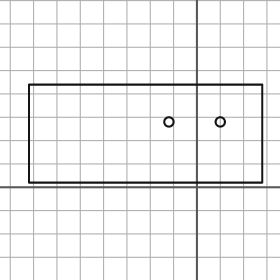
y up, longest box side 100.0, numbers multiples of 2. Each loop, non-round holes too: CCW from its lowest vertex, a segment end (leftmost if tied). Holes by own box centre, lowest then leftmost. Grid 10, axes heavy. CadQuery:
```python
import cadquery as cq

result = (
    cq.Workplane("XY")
    .moveTo(-72.0, 2.0)
    .lineTo(28.0, 2.0)
    .lineTo(28.0, 44.0)
    .lineTo(-72.0, 44.0)
    .close()
    .moveTo(-12.0, 28.0)
    .circle(2.0)
    .moveTo(10.0, 28.0)
    .circle(2.0)
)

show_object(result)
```